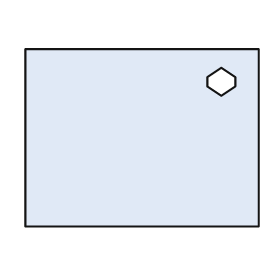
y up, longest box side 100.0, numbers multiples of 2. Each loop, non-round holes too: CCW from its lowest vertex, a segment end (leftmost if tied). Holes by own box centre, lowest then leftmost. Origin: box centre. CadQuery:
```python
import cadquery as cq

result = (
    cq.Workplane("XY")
    .moveTo(-50.0, -38.0)
    .lineTo(50.0, -38.0)
    .lineTo(50.0, 38.0)
    .lineTo(-50.0, 38.0)
    .close()
    .moveTo(34.0, 18.0)
    .lineTo(40.0, 22.0)
    .lineTo(40.0, 26.0)
    .lineTo(34.0, 30.0)
    .lineTo(28.0, 26.0)
    .lineTo(28.0, 22.0)
    .close()
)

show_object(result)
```